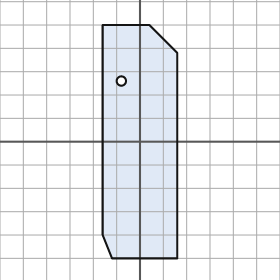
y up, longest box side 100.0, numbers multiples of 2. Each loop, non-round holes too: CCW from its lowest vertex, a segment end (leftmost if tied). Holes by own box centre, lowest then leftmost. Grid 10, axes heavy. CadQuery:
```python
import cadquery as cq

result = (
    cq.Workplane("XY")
    .moveTo(-12.0, -50.0)
    .lineTo(16.0, -50.0)
    .lineTo(16.0, 38.0)
    .lineTo(4.0, 50.0)
    .lineTo(-16.0, 50.0)
    .lineTo(-16.0, -40.0)
    .close()
    .moveTo(-8.0, 26.0)
    .circle(2.0)
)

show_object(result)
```